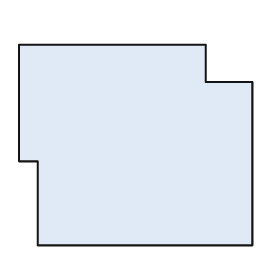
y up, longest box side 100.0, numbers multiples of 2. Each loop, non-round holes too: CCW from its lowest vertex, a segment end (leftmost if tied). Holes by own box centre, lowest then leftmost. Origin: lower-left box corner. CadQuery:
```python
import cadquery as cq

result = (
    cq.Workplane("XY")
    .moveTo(8.0, 0.0)
    .lineTo(100.0, 0.0)
    .lineTo(100.0, 70.0)
    .lineTo(80.0, 70.0)
    .lineTo(80.0, 86.0)
    .lineTo(0.0, 86.0)
    .lineTo(0.0, 36.0)
    .lineTo(8.0, 36.0)
    .close()
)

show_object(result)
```